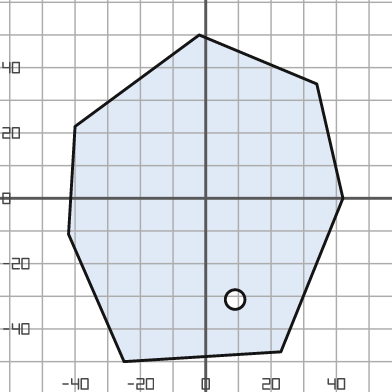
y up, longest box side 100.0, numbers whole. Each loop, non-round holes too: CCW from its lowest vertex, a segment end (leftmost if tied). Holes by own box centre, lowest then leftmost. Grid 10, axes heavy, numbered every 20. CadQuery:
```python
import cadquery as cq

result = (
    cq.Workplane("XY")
    .moveTo(-25.0, -50.0)
    .lineTo(23.0, -47.0)
    .lineTo(42.0, 0.0)
    .lineTo(34.0, 35.0)
    .lineTo(-2.0, 50.0)
    .lineTo(-40.0, 22.0)
    .lineTo(-42.0, -11.0)
    .close()
    .moveTo(9.0, -31.0)
    .circle(3.0)
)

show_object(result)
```